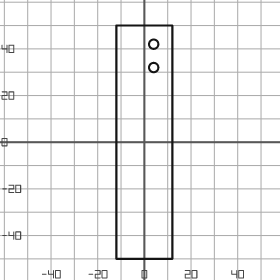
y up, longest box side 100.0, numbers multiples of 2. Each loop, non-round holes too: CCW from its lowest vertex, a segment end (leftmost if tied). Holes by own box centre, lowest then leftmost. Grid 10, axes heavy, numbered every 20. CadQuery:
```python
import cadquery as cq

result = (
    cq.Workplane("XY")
    .moveTo(-12.0, -50.0)
    .lineTo(12.0, -50.0)
    .lineTo(12.0, 50.0)
    .lineTo(-12.0, 50.0)
    .close()
    .moveTo(4.0, 32.0)
    .circle(2.0)
    .moveTo(4.0, 42.0)
    .circle(2.0)
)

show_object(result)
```